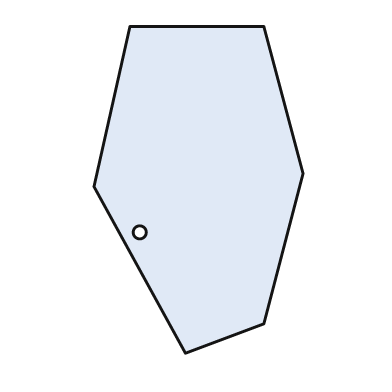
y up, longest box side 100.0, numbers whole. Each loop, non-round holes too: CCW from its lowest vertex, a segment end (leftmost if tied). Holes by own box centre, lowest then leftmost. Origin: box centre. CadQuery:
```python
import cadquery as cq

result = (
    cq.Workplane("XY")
    .moveTo(-4.0, -50.0)
    .lineTo(20.0, -41.0)
    .lineTo(32.0, 5.0)
    .lineTo(20.0, 50.0)
    .lineTo(-21.0, 50.0)
    .lineTo(-32.0, 1.0)
    .close()
    .moveTo(-18.0, -13.0)
    .circle(2.0)
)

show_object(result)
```